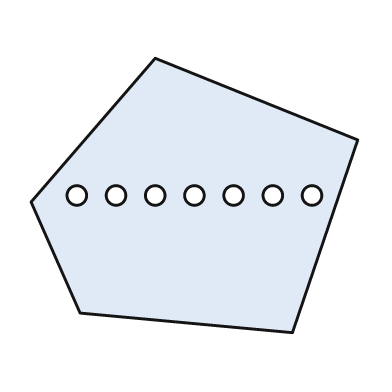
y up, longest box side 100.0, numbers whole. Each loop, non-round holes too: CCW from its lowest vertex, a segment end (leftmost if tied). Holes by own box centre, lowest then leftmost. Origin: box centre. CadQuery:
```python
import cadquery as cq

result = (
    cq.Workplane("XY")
    .moveTo(30.0, -42.0)
    .lineTo(50.0, 17.0)
    .lineTo(-12.0, 42.0)
    .lineTo(-50.0, -2.0)
    .lineTo(-35.0, -36.0)
    .close()
    .moveTo(-36.0, 0.0)
    .circle(3.0)
    .moveTo(-24.0, 0.0)
    .circle(3.0)
    .moveTo(-12.0, 0.0)
    .circle(3.0)
    .moveTo(0.0, 0.0)
    .circle(3.0)
    .moveTo(12.0, 0.0)
    .circle(3.0)
    .moveTo(24.0, 0.0)
    .circle(3.0)
    .moveTo(36.0, 0.0)
    .circle(3.0)
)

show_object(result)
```